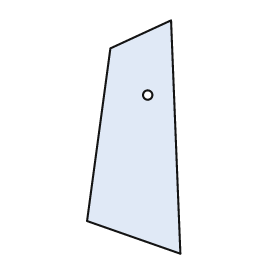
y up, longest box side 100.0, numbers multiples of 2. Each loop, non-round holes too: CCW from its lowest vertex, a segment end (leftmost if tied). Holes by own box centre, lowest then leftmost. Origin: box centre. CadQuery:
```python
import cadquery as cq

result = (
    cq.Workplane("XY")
    .moveTo(20.0, -50.0)
    .lineTo(16.0, 50.0)
    .lineTo(-10.0, 38.0)
    .lineTo(-20.0, -36.0)
    .close()
    .moveTo(6.0, 18.0)
    .circle(2.0)
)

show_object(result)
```